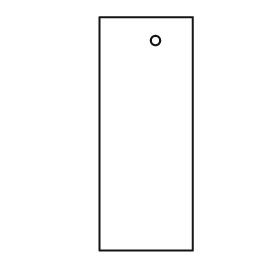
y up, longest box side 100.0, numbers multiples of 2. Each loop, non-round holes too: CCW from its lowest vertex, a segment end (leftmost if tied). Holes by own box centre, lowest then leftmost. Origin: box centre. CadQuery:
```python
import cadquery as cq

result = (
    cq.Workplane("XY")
    .moveTo(-20.0, -50.0)
    .lineTo(20.0, -50.0)
    .lineTo(20.0, 50.0)
    .lineTo(-20.0, 50.0)
    .close()
    .moveTo(4.0, 40.0)
    .circle(2.0)
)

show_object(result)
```